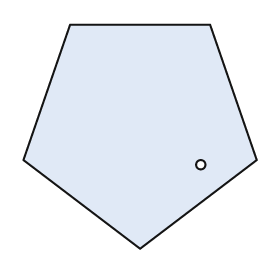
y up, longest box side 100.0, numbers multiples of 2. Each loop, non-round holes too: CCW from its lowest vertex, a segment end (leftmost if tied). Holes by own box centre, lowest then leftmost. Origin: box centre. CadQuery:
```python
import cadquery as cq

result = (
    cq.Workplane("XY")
    .moveTo(0.0, -48.0)
    .lineTo(50.0, -10.0)
    .lineTo(30.0, 48.0)
    .lineTo(-30.0, 48.0)
    .lineTo(-50.0, -10.0)
    .close()
    .moveTo(26.0, -12.0)
    .circle(2.0)
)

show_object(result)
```